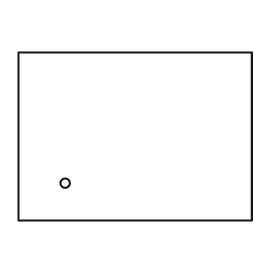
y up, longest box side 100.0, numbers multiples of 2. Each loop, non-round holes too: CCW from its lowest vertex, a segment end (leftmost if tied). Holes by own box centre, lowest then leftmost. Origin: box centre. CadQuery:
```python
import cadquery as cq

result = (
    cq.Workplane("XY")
    .moveTo(-50.0, -36.0)
    .lineTo(50.0, -36.0)
    .lineTo(50.0, 36.0)
    .lineTo(-50.0, 36.0)
    .close()
    .moveTo(-30.0, -20.0)
    .circle(2.0)
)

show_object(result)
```